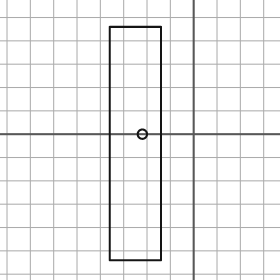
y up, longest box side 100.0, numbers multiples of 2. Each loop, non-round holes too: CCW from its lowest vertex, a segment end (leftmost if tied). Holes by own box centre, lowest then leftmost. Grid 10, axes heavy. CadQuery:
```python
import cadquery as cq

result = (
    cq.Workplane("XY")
    .moveTo(-36.0, -54.0)
    .lineTo(-14.0, -54.0)
    .lineTo(-14.0, 46.0)
    .lineTo(-36.0, 46.0)
    .close()
    .moveTo(-22.0, 0.0)
    .circle(2.0)
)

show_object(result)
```